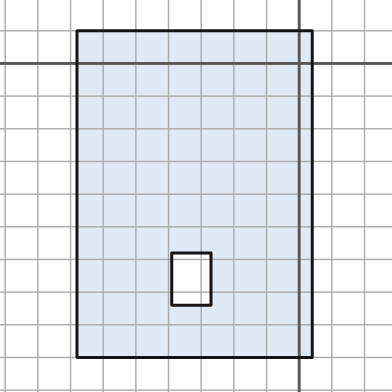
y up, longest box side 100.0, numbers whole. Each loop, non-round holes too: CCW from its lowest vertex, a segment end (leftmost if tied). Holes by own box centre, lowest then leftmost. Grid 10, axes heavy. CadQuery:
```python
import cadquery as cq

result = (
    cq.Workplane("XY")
    .moveTo(-68.0, -90.0)
    .lineTo(4.0, -90.0)
    .lineTo(4.0, 10.0)
    .lineTo(-68.0, 10.0)
    .close()
    .moveTo(-39.0, -74.0)
    .lineTo(-27.0, -74.0)
    .lineTo(-27.0, -58.0)
    .lineTo(-39.0, -58.0)
    .close()
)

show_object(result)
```